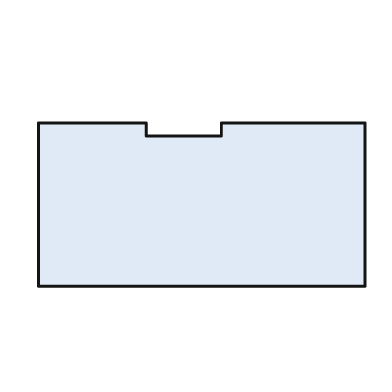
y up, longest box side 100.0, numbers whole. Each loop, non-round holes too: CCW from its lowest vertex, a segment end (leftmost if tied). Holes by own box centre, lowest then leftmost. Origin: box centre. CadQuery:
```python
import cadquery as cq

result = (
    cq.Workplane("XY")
    .moveTo(-50.0, -25.0)
    .lineTo(50.0, -25.0)
    .lineTo(50.0, 25.0)
    .lineTo(6.0, 25.0)
    .lineTo(6.0, 21.0)
    .lineTo(-17.0, 21.0)
    .lineTo(-17.0, 25.0)
    .lineTo(-50.0, 25.0)
    .close()
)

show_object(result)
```